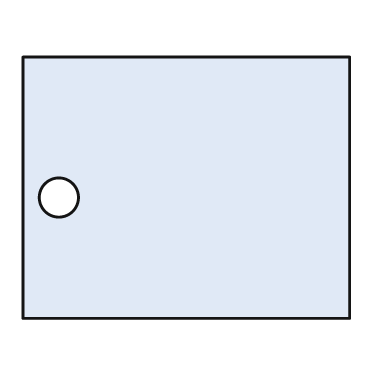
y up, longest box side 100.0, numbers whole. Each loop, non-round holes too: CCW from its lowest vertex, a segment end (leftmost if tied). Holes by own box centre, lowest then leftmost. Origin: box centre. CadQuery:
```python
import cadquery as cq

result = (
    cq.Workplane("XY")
    .moveTo(-50.0, -40.0)
    .lineTo(50.0, -40.0)
    .lineTo(50.0, 40.0)
    .lineTo(-50.0, 40.0)
    .close()
    .moveTo(-39.0, -3.0)
    .circle(6.0)
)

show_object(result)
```